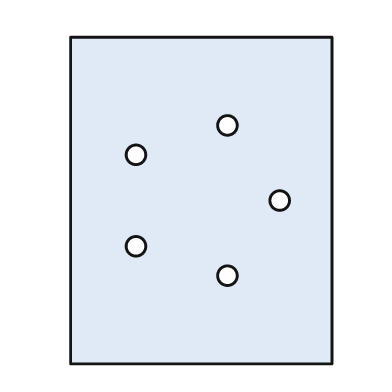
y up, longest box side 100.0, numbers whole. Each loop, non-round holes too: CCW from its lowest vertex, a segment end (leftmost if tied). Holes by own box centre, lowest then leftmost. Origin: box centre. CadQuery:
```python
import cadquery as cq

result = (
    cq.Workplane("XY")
    .moveTo(-40.0, -50.0)
    .lineTo(40.0, -50.0)
    .lineTo(40.0, 50.0)
    .lineTo(-40.0, 50.0)
    .close()
    .moveTo(8.0, -23.0)
    .circle(3.0)
    .moveTo(-20.0, -14.0)
    .circle(3.0)
    .moveTo(24.0, 0.0)
    .circle(3.0)
    .moveTo(-20.0, 14.0)
    .circle(3.0)
    .moveTo(8.0, 23.0)
    .circle(3.0)
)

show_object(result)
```